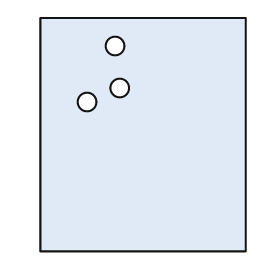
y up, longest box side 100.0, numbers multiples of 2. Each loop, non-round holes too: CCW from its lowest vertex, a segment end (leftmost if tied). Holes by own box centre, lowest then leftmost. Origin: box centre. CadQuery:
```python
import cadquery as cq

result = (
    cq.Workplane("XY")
    .moveTo(-44.0, -50.0)
    .lineTo(44.0, -50.0)
    .lineTo(44.0, 50.0)
    .lineTo(-44.0, 50.0)
    .close()
    .moveTo(-24.0, 14.0)
    .circle(4.0)
    .moveTo(-10.0, 20.0)
    .circle(4.0)
    .moveTo(-12.0, 38.0)
    .circle(4.0)
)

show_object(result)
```